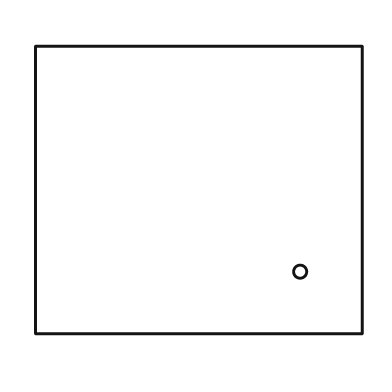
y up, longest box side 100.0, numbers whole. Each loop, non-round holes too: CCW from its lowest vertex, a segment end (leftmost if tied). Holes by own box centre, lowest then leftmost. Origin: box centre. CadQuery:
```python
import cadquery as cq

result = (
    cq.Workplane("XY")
    .moveTo(-50.0, -44.0)
    .lineTo(50.0, -44.0)
    .lineTo(50.0, 44.0)
    .lineTo(-50.0, 44.0)
    .close()
    .moveTo(31.0, -25.0)
    .circle(2.0)
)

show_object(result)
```